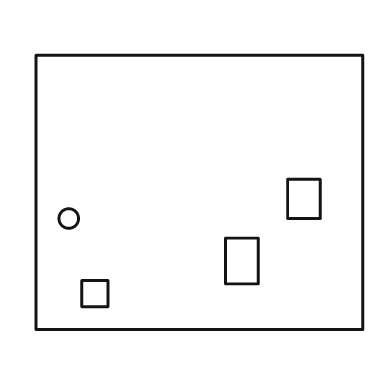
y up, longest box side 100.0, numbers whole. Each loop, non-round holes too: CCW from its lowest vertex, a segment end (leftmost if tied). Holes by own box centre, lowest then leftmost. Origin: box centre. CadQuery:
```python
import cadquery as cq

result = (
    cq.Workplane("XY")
    .moveTo(-50.0, -42.0)
    .lineTo(50.0, -42.0)
    .lineTo(50.0, 42.0)
    .lineTo(-50.0, 42.0)
    .close()
    .moveTo(-36.0, -35.0)
    .lineTo(-28.0, -35.0)
    .lineTo(-28.0, -27.0)
    .lineTo(-36.0, -27.0)
    .close()
    .moveTo(8.0, -28.0)
    .lineTo(18.0, -28.0)
    .lineTo(18.0, -14.0)
    .lineTo(8.0, -14.0)
    .close()
    .moveTo(-40.0, -8.0)
    .circle(3.0)
    .moveTo(27.0, -8.0)
    .lineTo(37.0, -8.0)
    .lineTo(37.0, 4.0)
    .lineTo(27.0, 4.0)
    .close()
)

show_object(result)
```